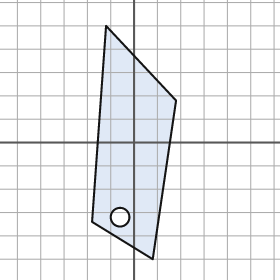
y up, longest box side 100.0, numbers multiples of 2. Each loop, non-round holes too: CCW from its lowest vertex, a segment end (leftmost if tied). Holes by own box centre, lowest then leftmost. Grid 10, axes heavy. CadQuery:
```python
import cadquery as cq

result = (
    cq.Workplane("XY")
    .moveTo(8.0, -50.0)
    .lineTo(18.0, 18.0)
    .lineTo(-12.0, 50.0)
    .lineTo(-18.0, -34.0)
    .close()
    .moveTo(-6.0, -32.0)
    .circle(4.0)
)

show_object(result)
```